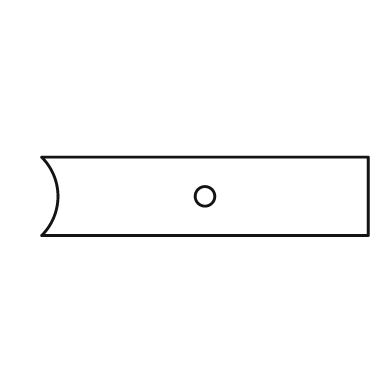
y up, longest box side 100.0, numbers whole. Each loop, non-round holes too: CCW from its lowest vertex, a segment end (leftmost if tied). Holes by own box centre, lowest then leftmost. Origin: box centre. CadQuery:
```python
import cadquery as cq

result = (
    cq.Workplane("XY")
    .moveTo(-50.0, -12.0)
    .lineTo(50.0, -12.0)
    .lineTo(50.0, 12.0)
    .lineTo(-50.0, 12.0)
    .threePointArc((-45.0, 0.0), (-50.0, -12.0))
    .close()
    .moveTo(0.0, 0.0)
    .circle(3.0)
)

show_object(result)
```